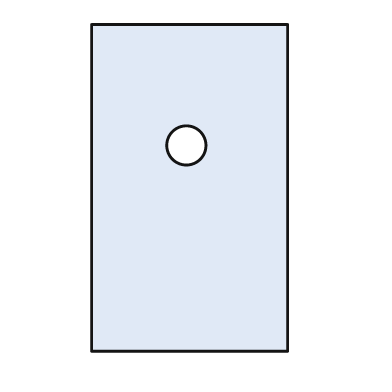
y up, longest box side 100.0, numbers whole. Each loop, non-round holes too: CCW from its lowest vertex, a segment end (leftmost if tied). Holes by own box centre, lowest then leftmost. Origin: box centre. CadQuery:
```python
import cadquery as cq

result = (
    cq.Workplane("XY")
    .moveTo(-30.0, -50.0)
    .lineTo(30.0, -50.0)
    .lineTo(30.0, 50.0)
    .lineTo(-30.0, 50.0)
    .close()
    .moveTo(-1.0, 13.0)
    .circle(6.0)
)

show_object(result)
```